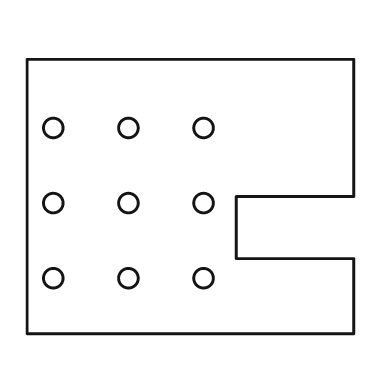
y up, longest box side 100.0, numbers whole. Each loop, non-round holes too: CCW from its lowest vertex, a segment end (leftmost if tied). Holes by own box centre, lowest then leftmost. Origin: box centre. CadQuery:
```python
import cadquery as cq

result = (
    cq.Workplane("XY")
    .moveTo(-50.0, -42.0)
    .lineTo(50.0, -42.0)
    .lineTo(50.0, -19.0)
    .lineTo(14.0, -19.0)
    .lineTo(14.0, 0.0)
    .lineTo(50.0, 0.0)
    .lineTo(50.0, 42.0)
    .lineTo(-50.0, 42.0)
    .close()
    .moveTo(-42.0, -25.0)
    .circle(3.0)
    .moveTo(-19.0, -25.0)
    .circle(3.0)
    .moveTo(4.0, -25.0)
    .circle(3.0)
    .moveTo(-42.0, -2.0)
    .circle(3.0)
    .moveTo(-19.0, -2.0)
    .circle(3.0)
    .moveTo(4.0, -2.0)
    .circle(3.0)
    .moveTo(-42.0, 21.0)
    .circle(3.0)
    .moveTo(-19.0, 21.0)
    .circle(3.0)
    .moveTo(4.0, 21.0)
    .circle(3.0)
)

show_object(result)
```